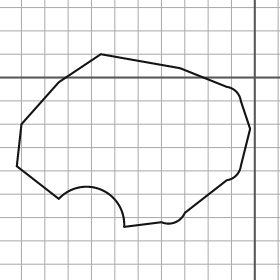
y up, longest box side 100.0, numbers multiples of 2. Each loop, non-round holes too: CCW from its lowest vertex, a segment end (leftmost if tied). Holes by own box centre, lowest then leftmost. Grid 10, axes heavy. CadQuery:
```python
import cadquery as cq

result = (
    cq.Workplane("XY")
    .moveTo(-56.0, -64.0)
    .lineTo(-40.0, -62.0)
    .threePointArc((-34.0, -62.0), (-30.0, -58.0))
    .lineTo(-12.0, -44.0)
    .threePointArc((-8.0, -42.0), (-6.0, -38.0))
    .lineTo(-2.0, -22.0)
    .lineTo(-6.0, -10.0)
    .threePointArc((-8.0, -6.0), (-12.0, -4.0))
    .lineTo(-32.0, 4.0)
    .lineTo(-66.0, 10.0)
    .lineTo(-84.0, -2.0)
    .lineTo(-100.0, -20.0)
    .lineTo(-102.0, -38.0)
    .lineTo(-84.0, -52.0)
    .threePointArc((-66.0, -48.0), (-56.0, -64.0))
    .close()
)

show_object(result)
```